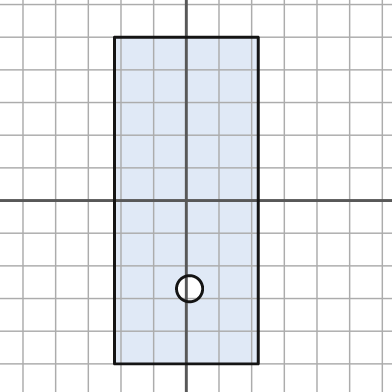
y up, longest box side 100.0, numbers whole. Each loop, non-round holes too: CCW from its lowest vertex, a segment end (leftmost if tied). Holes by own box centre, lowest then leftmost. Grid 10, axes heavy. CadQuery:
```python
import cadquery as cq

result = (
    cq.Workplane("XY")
    .moveTo(-22.0, -50.0)
    .lineTo(22.0, -50.0)
    .lineTo(22.0, 50.0)
    .lineTo(-22.0, 50.0)
    .close()
    .moveTo(1.0, -27.0)
    .circle(4.0)
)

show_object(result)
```